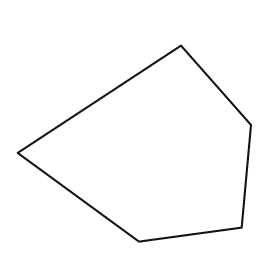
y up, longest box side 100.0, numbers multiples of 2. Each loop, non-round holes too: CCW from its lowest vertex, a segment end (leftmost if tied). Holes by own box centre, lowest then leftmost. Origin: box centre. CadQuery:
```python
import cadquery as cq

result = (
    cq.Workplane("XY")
    .moveTo(2.0, -42.0)
    .lineTo(46.0, -36.0)
    .lineTo(50.0, 8.0)
    .lineTo(20.0, 42.0)
    .lineTo(-50.0, -4.0)
    .close()
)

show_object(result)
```